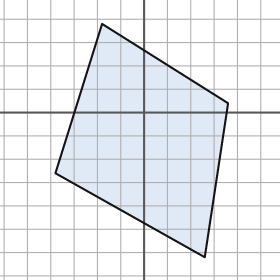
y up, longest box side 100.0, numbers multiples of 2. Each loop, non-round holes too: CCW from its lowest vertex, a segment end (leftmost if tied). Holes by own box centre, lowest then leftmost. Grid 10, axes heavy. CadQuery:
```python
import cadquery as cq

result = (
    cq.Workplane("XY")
    .moveTo(26.0, -62.0)
    .lineTo(36.0, 4.0)
    .lineTo(-18.0, 38.0)
    .lineTo(-38.0, -26.0)
    .close()
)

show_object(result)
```